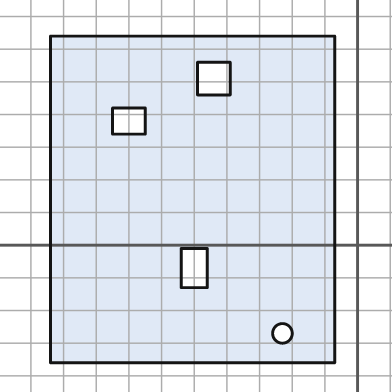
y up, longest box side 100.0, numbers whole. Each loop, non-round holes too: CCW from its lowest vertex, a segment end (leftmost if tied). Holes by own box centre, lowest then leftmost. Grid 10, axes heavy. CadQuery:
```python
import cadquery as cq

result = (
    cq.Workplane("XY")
    .moveTo(-94.0, -36.0)
    .lineTo(-7.0, -36.0)
    .lineTo(-7.0, 64.0)
    .lineTo(-94.0, 64.0)
    .close()
    .moveTo(-23.0, -27.0)
    .circle(3.0)
    .moveTo(-54.0, -13.0)
    .lineTo(-46.0, -13.0)
    .lineTo(-46.0, -1.0)
    .lineTo(-54.0, -1.0)
    .close()
    .moveTo(-75.0, 34.0)
    .lineTo(-65.0, 34.0)
    .lineTo(-65.0, 42.0)
    .lineTo(-75.0, 42.0)
    .close()
    .moveTo(-49.0, 46.0)
    .lineTo(-39.0, 46.0)
    .lineTo(-39.0, 56.0)
    .lineTo(-49.0, 56.0)
    .close()
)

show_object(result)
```